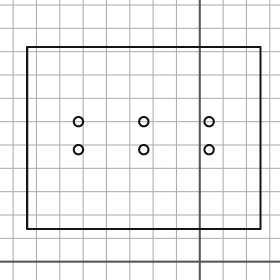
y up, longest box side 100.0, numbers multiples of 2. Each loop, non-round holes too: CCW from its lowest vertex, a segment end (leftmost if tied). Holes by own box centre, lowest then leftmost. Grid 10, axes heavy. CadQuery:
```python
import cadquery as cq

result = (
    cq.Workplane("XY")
    .moveTo(-74.0, 14.0)
    .lineTo(26.0, 14.0)
    .lineTo(26.0, 92.0)
    .lineTo(-74.0, 92.0)
    .close()
    .moveTo(-52.0, 48.0)
    .circle(2.0)
    .moveTo(-24.0, 48.0)
    .circle(2.0)
    .moveTo(4.0, 48.0)
    .circle(2.0)
    .moveTo(-52.0, 60.0)
    .circle(2.0)
    .moveTo(-24.0, 60.0)
    .circle(2.0)
    .moveTo(4.0, 60.0)
    .circle(2.0)
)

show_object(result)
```